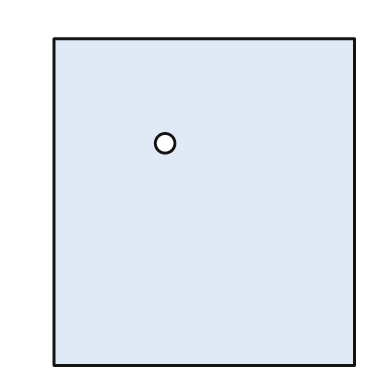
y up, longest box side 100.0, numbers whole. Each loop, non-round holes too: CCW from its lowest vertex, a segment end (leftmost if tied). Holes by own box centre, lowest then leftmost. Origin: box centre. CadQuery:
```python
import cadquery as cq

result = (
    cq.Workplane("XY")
    .moveTo(-46.0, -50.0)
    .lineTo(46.0, -50.0)
    .lineTo(46.0, 50.0)
    .lineTo(-46.0, 50.0)
    .close()
    .moveTo(-12.0, 18.0)
    .circle(3.0)
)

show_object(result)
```